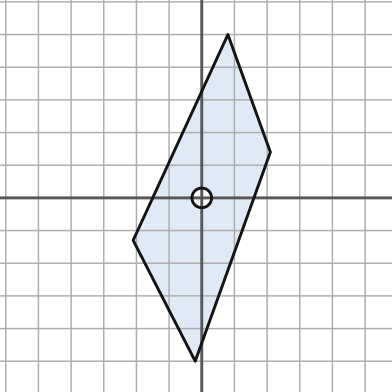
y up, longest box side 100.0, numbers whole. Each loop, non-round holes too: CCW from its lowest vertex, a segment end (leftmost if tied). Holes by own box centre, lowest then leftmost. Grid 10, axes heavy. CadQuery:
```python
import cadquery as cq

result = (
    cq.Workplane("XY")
    .moveTo(-2.0, -50.0)
    .lineTo(21.0, 14.0)
    .lineTo(8.0, 50.0)
    .lineTo(-21.0, -13.0)
    .close()
    .moveTo(0.0, 0.0)
    .circle(3.0)
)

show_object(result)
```